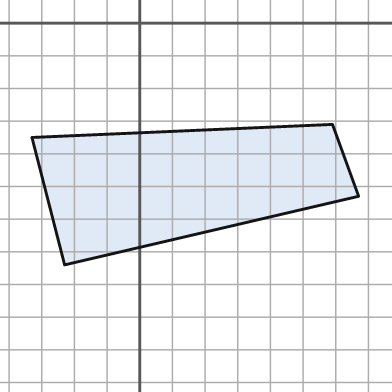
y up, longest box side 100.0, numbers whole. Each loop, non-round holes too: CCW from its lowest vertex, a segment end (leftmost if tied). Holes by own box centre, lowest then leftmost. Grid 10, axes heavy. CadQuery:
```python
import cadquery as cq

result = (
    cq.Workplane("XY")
    .moveTo(-23.0, -74.0)
    .lineTo(67.0, -53.0)
    .lineTo(59.0, -31.0)
    .lineTo(-33.0, -35.0)
    .close()
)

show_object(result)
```